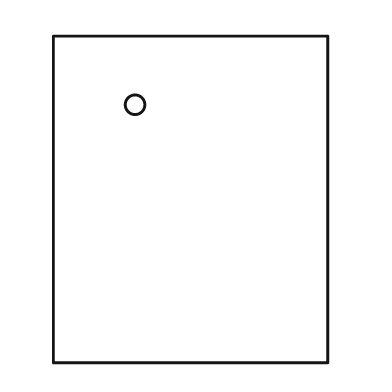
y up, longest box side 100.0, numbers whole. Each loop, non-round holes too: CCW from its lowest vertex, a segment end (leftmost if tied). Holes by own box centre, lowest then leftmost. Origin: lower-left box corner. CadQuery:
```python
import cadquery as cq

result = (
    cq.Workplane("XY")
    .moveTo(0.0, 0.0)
    .lineTo(84.0, 0.0)
    .lineTo(84.0, 100.0)
    .lineTo(0.0, 100.0)
    .close()
    .moveTo(25.0, 79.0)
    .circle(3.0)
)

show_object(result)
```